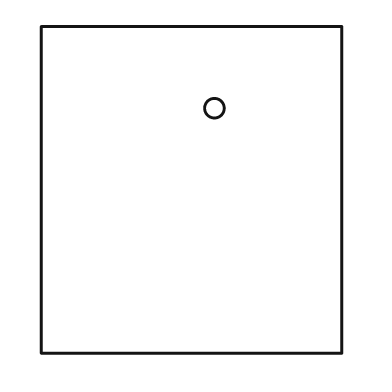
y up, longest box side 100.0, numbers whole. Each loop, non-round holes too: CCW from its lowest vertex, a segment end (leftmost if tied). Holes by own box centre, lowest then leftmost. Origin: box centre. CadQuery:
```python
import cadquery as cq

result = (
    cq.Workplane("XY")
    .moveTo(-46.0, -50.0)
    .lineTo(46.0, -50.0)
    .lineTo(46.0, 50.0)
    .lineTo(-46.0, 50.0)
    .close()
    .moveTo(7.0, 25.0)
    .circle(3.0)
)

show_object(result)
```